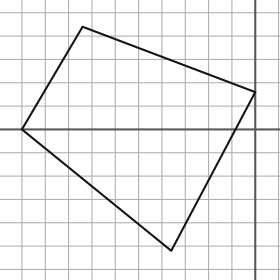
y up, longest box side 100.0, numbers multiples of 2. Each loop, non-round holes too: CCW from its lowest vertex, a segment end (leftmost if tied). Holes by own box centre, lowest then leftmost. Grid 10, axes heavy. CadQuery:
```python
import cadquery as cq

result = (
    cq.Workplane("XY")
    .moveTo(-36.0, -52.0)
    .lineTo(0.0, 16.0)
    .lineTo(-74.0, 44.0)
    .lineTo(-100.0, 0.0)
    .close()
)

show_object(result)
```